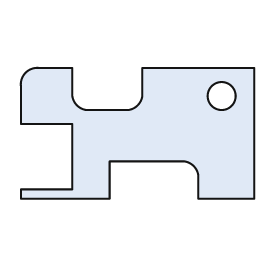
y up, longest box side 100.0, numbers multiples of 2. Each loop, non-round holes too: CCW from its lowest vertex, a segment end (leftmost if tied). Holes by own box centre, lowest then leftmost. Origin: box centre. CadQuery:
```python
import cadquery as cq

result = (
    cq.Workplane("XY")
    .moveTo(-50.0, -28.0)
    .lineTo(-12.0, -28.0)
    .lineTo(-12.0, -12.0)
    .lineTo(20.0, -12.0)
    .threePointArc((24.0, -14.0), (26.0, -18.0))
    .lineTo(26.0, -28.0)
    .lineTo(50.0, -28.0)
    .lineTo(50.0, 28.0)
    .lineTo(2.0, 28.0)
    .lineTo(2.0, 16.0)
    .threePointArc((0.0, 12.0), (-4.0, 10.0))
    .lineTo(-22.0, 10.0)
    .threePointArc((-26.0, 12.0), (-28.0, 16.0))
    .lineTo(-28.0, 28.0)
    .lineTo(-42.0, 28.0)
    .threePointArc((-48.0, 26.0), (-50.0, 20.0))
    .lineTo(-50.0, 4.0)
    .lineTo(-28.0, 4.0)
    .lineTo(-28.0, -24.0)
    .lineTo(-50.0, -24.0)
    .close()
    .moveTo(36.0, 16.0)
    .circle(6.0)
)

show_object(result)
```